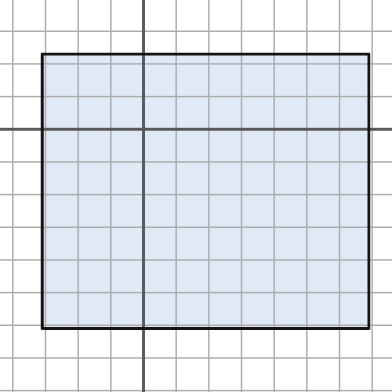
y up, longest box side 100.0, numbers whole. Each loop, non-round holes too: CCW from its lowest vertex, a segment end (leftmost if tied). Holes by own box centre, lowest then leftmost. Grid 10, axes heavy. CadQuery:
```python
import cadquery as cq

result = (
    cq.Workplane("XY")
    .moveTo(-31.0, -61.0)
    .lineTo(69.0, -61.0)
    .lineTo(69.0, 23.0)
    .lineTo(-31.0, 23.0)
    .close()
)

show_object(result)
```